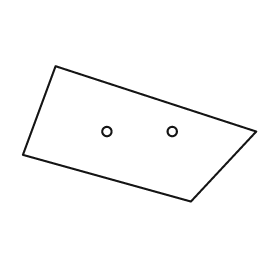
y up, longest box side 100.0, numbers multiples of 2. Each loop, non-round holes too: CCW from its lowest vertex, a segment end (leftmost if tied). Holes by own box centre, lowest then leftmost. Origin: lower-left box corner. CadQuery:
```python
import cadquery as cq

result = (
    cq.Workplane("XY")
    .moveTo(72.0, 0.0)
    .lineTo(100.0, 30.0)
    .lineTo(14.0, 58.0)
    .lineTo(0.0, 20.0)
    .close()
    .moveTo(36.0, 30.0)
    .circle(2.0)
    .moveTo(64.0, 30.0)
    .circle(2.0)
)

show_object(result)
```